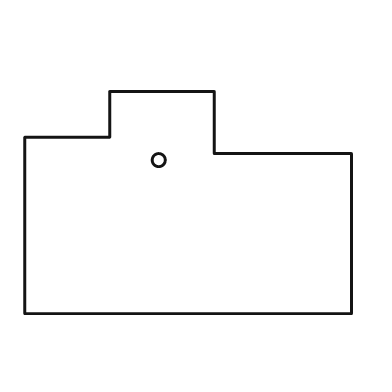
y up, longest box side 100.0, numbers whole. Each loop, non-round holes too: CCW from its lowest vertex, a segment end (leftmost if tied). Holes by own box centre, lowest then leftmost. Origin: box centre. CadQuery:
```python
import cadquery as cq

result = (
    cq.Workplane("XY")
    .moveTo(-50.0, -34.0)
    .lineTo(50.0, -34.0)
    .lineTo(50.0, 15.0)
    .lineTo(8.0, 15.0)
    .lineTo(8.0, 34.0)
    .lineTo(-24.0, 34.0)
    .lineTo(-24.0, 20.0)
    .lineTo(-50.0, 20.0)
    .close()
    .moveTo(-9.0, 13.0)
    .circle(2.0)
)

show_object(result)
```